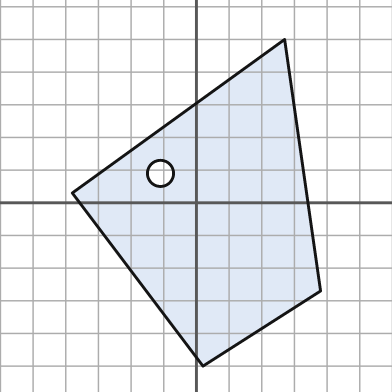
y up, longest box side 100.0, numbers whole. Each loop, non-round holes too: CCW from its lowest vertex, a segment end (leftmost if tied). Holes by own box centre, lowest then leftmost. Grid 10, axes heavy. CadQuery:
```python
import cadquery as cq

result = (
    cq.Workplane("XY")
    .moveTo(2.0, -50.0)
    .lineTo(38.0, -27.0)
    .lineTo(27.0, 50.0)
    .lineTo(-38.0, 3.0)
    .close()
    .moveTo(-11.0, 9.0)
    .circle(4.0)
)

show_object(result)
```